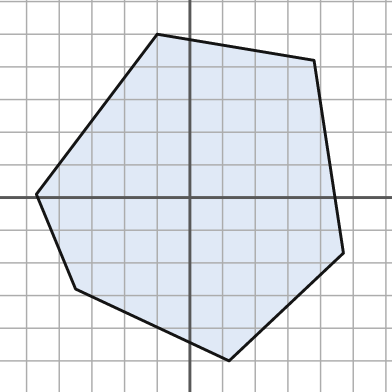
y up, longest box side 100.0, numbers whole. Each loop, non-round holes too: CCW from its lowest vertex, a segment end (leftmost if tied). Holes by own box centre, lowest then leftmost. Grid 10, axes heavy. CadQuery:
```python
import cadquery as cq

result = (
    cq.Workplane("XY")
    .moveTo(12.0, -50.0)
    .lineTo(47.0, -17.0)
    .lineTo(38.0, 42.0)
    .lineTo(-10.0, 50.0)
    .lineTo(-47.0, 1.0)
    .lineTo(-35.0, -28.0)
    .close()
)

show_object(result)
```